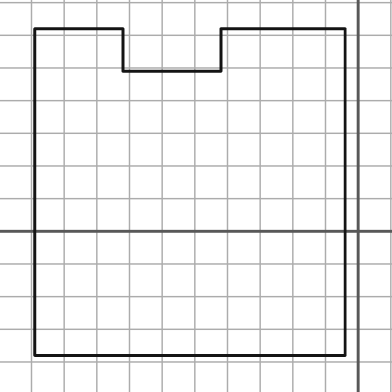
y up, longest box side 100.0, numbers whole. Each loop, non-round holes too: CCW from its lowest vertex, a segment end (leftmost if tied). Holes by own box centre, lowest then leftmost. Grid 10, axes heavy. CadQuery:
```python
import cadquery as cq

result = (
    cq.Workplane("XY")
    .moveTo(-99.0, -38.0)
    .lineTo(-4.0, -38.0)
    .lineTo(-4.0, 62.0)
    .lineTo(-42.0, 62.0)
    .lineTo(-42.0, 49.0)
    .lineTo(-72.0, 49.0)
    .lineTo(-72.0, 62.0)
    .lineTo(-99.0, 62.0)
    .close()
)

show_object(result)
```